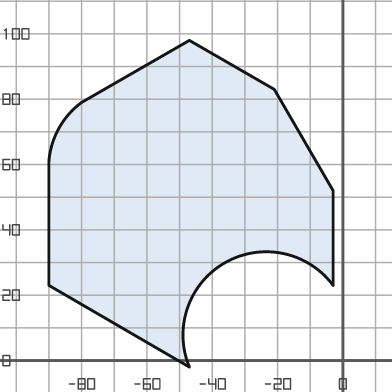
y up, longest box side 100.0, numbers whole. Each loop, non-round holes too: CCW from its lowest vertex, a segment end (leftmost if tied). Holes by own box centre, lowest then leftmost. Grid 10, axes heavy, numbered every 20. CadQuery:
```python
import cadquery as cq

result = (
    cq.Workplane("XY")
    .moveTo(-47.0, -2.0)
    .threePointArc((-36.0, 30.0), (-3.0, 23.0))
    .lineTo(-3.0, 52.0)
    .lineTo(-21.0, 83.0)
    .lineTo(-47.0, 98.0)
    .lineTo(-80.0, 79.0)
    .threePointArc((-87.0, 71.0), (-90.0, 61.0))
    .lineTo(-90.0, 23.0)
    .close()
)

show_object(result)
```